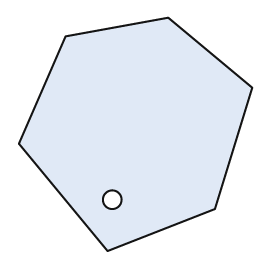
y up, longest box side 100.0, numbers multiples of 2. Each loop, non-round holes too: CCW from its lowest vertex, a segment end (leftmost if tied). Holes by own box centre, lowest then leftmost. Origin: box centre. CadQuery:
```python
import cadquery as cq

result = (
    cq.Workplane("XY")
    .moveTo(-12.0, -50.0)
    .lineTo(34.0, -32.0)
    .lineTo(50.0, 20.0)
    .lineTo(14.0, 50.0)
    .lineTo(-30.0, 42.0)
    .lineTo(-50.0, -4.0)
    .close()
    .moveTo(-10.0, -28.0)
    .circle(4.0)
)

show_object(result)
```